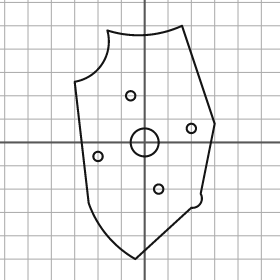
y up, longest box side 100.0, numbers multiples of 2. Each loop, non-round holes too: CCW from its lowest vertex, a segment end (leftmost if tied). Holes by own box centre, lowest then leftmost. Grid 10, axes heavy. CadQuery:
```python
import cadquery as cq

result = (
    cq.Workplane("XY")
    .moveTo(-4.0, -50.0)
    .lineTo(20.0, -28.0)
    .threePointArc((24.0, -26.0), (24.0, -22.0))
    .lineTo(30.0, 8.0)
    .lineTo(16.0, 50.0)
    .threePointArc((0.0, 46.0), (-16.0, 48.0))
    .threePointArc((-18.0, 34.0), (-30.0, 26.0))
    .lineTo(-24.0, -26.0)
    .threePointArc((-16.0, -40.0), (-4.0, -50.0))
    .close()
    .moveTo(6.0, -20.0)
    .circle(2.0)
    .moveTo(-20.0, -6.0)
    .circle(2.0)
    .moveTo(0.0, 0.0)
    .circle(6.0)
    .moveTo(20.0, 6.0)
    .circle(2.0)
    .moveTo(-6.0, 20.0)
    .circle(2.0)
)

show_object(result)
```